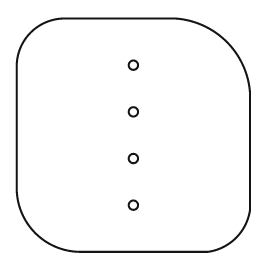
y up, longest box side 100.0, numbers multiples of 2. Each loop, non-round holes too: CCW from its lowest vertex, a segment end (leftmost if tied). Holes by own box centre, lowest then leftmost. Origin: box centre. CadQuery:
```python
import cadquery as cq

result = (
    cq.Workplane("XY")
    .moveTo(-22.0, -50.0)
    .lineTo(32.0, -50.0)
    .threePointArc((44.0, -44.0), (50.0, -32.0))
    .lineTo(50.0, 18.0)
    .threePointArc((40.0, 40.0), (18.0, 50.0))
    .lineTo(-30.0, 50.0)
    .threePointArc((-44.0, 44.0), (-50.0, 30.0))
    .lineTo(-50.0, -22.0)
    .threePointArc((-42.0, -42.0), (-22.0, -50.0))
    .close()
    .moveTo(0.0, -30.0)
    .circle(2.0)
    .moveTo(0.0, -10.0)
    .circle(2.0)
    .moveTo(0.0, 10.0)
    .circle(2.0)
    .moveTo(0.0, 30.0)
    .circle(2.0)
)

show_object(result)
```